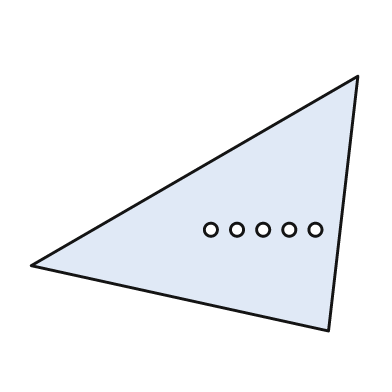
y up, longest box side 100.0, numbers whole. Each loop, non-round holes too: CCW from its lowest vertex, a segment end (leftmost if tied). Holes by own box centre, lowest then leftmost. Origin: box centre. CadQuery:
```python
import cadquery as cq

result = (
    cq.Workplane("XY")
    .moveTo(41.0, -39.0)
    .lineTo(50.0, 39.0)
    .lineTo(-50.0, -19.0)
    .close()
    .moveTo(5.0, -8.0)
    .circle(2.0)
    .moveTo(13.0, -8.0)
    .circle(2.0)
    .moveTo(21.0, -8.0)
    .circle(2.0)
    .moveTo(29.0, -8.0)
    .circle(2.0)
    .moveTo(37.0, -8.0)
    .circle(2.0)
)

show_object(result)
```